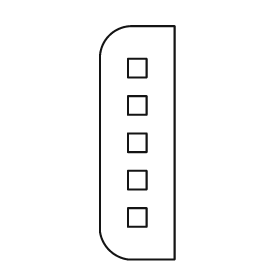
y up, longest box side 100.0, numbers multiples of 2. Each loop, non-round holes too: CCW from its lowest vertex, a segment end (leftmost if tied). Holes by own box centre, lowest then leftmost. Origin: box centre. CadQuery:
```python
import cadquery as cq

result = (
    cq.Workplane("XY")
    .moveTo(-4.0, -50.0)
    .lineTo(16.0, -50.0)
    .lineTo(16.0, 50.0)
    .lineTo(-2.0, 50.0)
    .threePointArc((-12.0, 46.0), (-16.0, 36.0))
    .lineTo(-16.0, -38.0)
    .threePointArc((-12.0, -46.0), (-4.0, -50.0))
    .close()
    .moveTo(-4.0, -36.0)
    .lineTo(4.0, -36.0)
    .lineTo(4.0, -28.0)
    .lineTo(-4.0, -28.0)
    .close()
    .moveTo(-4.0, -20.0)
    .lineTo(4.0, -20.0)
    .lineTo(4.0, -12.0)
    .lineTo(-4.0, -12.0)
    .close()
    .moveTo(-4.0, -4.0)
    .lineTo(4.0, -4.0)
    .lineTo(4.0, 4.0)
    .lineTo(-4.0, 4.0)
    .close()
    .moveTo(-4.0, 12.0)
    .lineTo(4.0, 12.0)
    .lineTo(4.0, 20.0)
    .lineTo(-4.0, 20.0)
    .close()
    .moveTo(-4.0, 28.0)
    .lineTo(4.0, 28.0)
    .lineTo(4.0, 36.0)
    .lineTo(-4.0, 36.0)
    .close()
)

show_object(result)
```